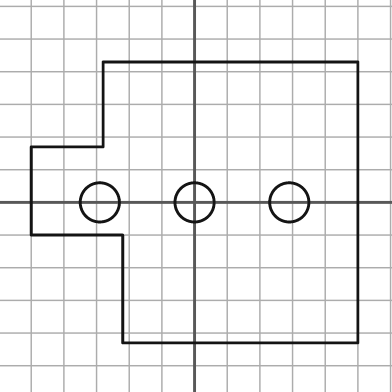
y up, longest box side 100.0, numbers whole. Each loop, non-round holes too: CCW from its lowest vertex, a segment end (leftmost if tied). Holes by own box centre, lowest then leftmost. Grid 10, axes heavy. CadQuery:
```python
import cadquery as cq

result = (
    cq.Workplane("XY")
    .moveTo(-22.0, -43.0)
    .lineTo(50.0, -43.0)
    .lineTo(50.0, 43.0)
    .lineTo(-28.0, 43.0)
    .lineTo(-28.0, 17.0)
    .lineTo(-50.0, 17.0)
    .lineTo(-50.0, -10.0)
    .lineTo(-22.0, -10.0)
    .close()
    .moveTo(-29.0, 0.0)
    .circle(6.0)
    .moveTo(0.0, 0.0)
    .circle(6.0)
    .moveTo(29.0, 0.0)
    .circle(6.0)
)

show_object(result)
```